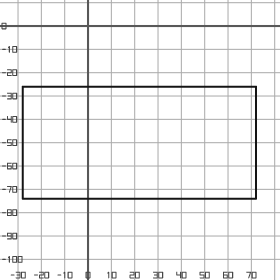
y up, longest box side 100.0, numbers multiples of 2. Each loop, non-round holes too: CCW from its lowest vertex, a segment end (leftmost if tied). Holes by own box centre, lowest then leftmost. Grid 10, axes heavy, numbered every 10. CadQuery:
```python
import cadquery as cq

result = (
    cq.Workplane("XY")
    .moveTo(-28.0, -74.0)
    .lineTo(72.0, -74.0)
    .lineTo(72.0, -26.0)
    .lineTo(-28.0, -26.0)
    .close()
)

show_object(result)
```